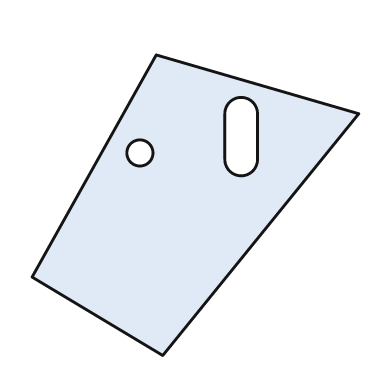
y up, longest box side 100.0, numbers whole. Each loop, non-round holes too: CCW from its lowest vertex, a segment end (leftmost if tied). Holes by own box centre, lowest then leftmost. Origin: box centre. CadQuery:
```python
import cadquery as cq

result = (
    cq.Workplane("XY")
    .moveTo(-10.0, -46.0)
    .lineTo(50.0, 28.0)
    .lineTo(-12.0, 46.0)
    .lineTo(-50.0, -22.0)
    .close()
    .moveTo(-17.0, 16.0)
    .circle(4.0)
    .moveTo(9.0, 14.0)
    .threePointArc((14.0, 9.0), (19.0, 14.0))
    .lineTo(19.0, 28.0)
    .threePointArc((14.0, 33.0), (9.0, 28.0))
    .close()
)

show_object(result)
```